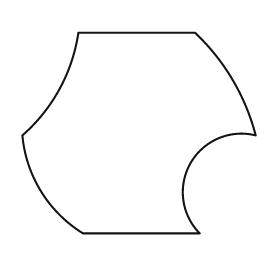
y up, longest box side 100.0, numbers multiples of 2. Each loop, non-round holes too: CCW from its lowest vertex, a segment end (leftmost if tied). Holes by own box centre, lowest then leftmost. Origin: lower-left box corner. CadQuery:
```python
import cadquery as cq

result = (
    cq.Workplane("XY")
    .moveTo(26.0, 0.0)
    .lineTo(76.0, 0.0)
    .threePointArc((72.0, 30.0), (100.0, 42.0))
    .threePointArc((90.0, 66.0), (74.0, 86.0))
    .lineTo(24.0, 86.0)
    .threePointArc((16.0, 62.0), (0.0, 42.0))
    .threePointArc((8.0, 18.0), (26.0, 0.0))
    .close()
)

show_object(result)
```